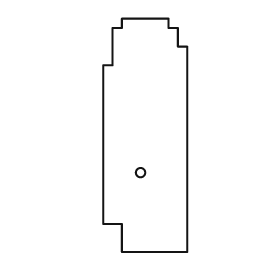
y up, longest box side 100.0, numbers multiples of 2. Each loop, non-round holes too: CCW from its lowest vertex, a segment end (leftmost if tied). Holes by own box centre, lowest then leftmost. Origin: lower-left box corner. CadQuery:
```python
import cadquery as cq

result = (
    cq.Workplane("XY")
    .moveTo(8.0, 0.0)
    .lineTo(36.0, 0.0)
    .lineTo(36.0, 88.0)
    .lineTo(32.0, 88.0)
    .lineTo(32.0, 96.0)
    .lineTo(28.0, 96.0)
    .lineTo(28.0, 100.0)
    .lineTo(8.0, 100.0)
    .lineTo(8.0, 96.0)
    .lineTo(4.0, 96.0)
    .lineTo(4.0, 80.0)
    .lineTo(0.0, 80.0)
    .lineTo(0.0, 12.0)
    .lineTo(8.0, 12.0)
    .close()
    .moveTo(16.0, 34.0)
    .circle(2.0)
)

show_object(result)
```